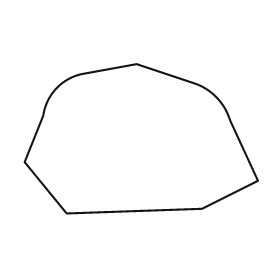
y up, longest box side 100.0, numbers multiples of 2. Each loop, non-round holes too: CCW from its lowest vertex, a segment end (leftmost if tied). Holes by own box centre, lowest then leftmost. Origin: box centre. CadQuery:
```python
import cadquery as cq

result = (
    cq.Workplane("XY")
    .moveTo(-32.0, -32.0)
    .lineTo(26.0, -30.0)
    .lineTo(50.0, -18.0)
    .lineTo(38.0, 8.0)
    .threePointArc((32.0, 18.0), (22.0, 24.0))
    .lineTo(-2.0, 32.0)
    .lineTo(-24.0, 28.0)
    .threePointArc((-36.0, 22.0), (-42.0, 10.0))
    .lineTo(-50.0, -10.0)
    .close()
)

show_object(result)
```